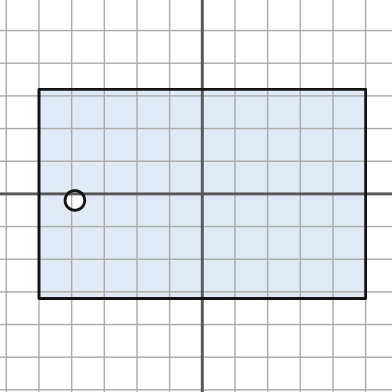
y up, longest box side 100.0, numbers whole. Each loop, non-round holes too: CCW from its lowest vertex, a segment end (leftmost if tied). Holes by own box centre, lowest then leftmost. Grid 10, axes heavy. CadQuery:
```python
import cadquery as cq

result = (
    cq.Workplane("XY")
    .moveTo(-50.0, -32.0)
    .lineTo(50.0, -32.0)
    .lineTo(50.0, 32.0)
    .lineTo(-50.0, 32.0)
    .close()
    .moveTo(-39.0, -2.0)
    .circle(3.0)
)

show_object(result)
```